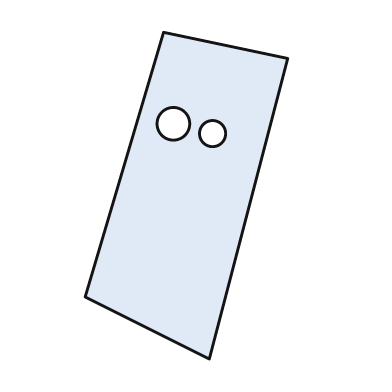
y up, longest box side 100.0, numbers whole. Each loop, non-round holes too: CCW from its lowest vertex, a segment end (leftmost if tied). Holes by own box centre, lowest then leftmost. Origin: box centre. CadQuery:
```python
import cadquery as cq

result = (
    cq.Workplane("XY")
    .moveTo(7.0, -50.0)
    .lineTo(31.0, 42.0)
    .lineTo(-7.0, 50.0)
    .lineTo(-31.0, -31.0)
    .close()
    .moveTo(8.0, 19.0)
    .circle(4.0)
    .moveTo(-4.0, 22.0)
    .circle(5.0)
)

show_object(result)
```